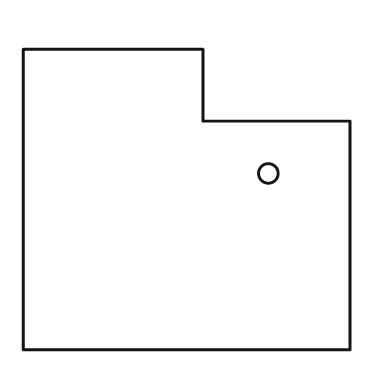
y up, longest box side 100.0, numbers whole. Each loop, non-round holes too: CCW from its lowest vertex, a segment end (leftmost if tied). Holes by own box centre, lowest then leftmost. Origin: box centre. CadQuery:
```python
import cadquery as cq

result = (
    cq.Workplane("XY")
    .moveTo(-50.0, -46.0)
    .lineTo(50.0, -46.0)
    .lineTo(50.0, 24.0)
    .lineTo(5.0, 24.0)
    .lineTo(5.0, 46.0)
    .lineTo(-50.0, 46.0)
    .close()
    .moveTo(25.0, 8.0)
    .circle(3.0)
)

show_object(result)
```